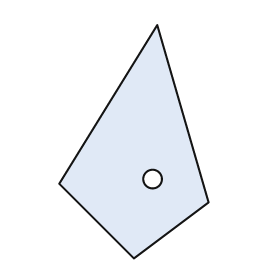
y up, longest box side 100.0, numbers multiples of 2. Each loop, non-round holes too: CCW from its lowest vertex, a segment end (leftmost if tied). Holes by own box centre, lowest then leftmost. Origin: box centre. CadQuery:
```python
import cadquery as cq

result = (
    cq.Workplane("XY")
    .moveTo(0.0, -50.0)
    .lineTo(32.0, -26.0)
    .lineTo(10.0, 50.0)
    .lineTo(-32.0, -18.0)
    .close()
    .moveTo(8.0, -16.0)
    .circle(4.0)
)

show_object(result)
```